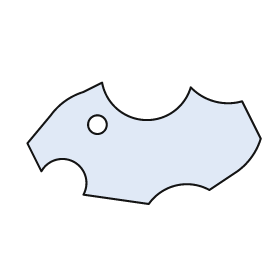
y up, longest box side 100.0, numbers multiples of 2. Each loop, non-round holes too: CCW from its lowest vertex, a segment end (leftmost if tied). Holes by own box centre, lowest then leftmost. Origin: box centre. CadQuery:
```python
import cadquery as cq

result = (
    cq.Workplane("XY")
    .moveTo(2.0, -26.0)
    .threePointArc((14.0, -18.0), (28.0, -20.0))
    .lineTo(40.0, -12.0)
    .threePointArc((46.0, -6.0), (50.0, 2.0))
    .lineTo(42.0, 18.0)
    .threePointArc((30.0, 18.0), (20.0, 24.0))
    .threePointArc((0.0, 10.0), (-18.0, 26.0))
    .lineTo(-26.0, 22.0)
    .threePointArc((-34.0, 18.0), (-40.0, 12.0))
    .lineTo(-50.0, 0.0)
    .lineTo(-44.0, -12.0)
    .threePointArc((-30.0, -8.0), (-26.0, -22.0))
    .close()
    .moveTo(-20.0, 8.0)
    .circle(4.0)
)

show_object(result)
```